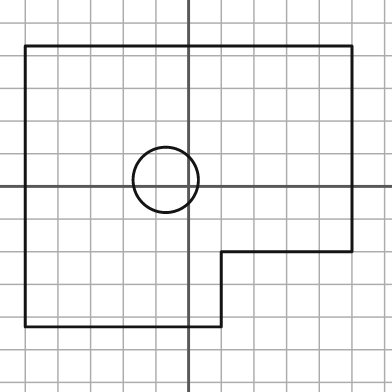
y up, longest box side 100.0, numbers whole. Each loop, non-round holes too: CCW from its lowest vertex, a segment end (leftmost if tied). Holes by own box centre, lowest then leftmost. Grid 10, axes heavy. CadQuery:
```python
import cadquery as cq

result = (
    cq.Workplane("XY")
    .moveTo(-50.0, -43.0)
    .lineTo(10.0, -43.0)
    .lineTo(10.0, -20.0)
    .lineTo(50.0, -20.0)
    .lineTo(50.0, 43.0)
    .lineTo(-50.0, 43.0)
    .close()
    .moveTo(-7.0, 2.0)
    .circle(10.0)
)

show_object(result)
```